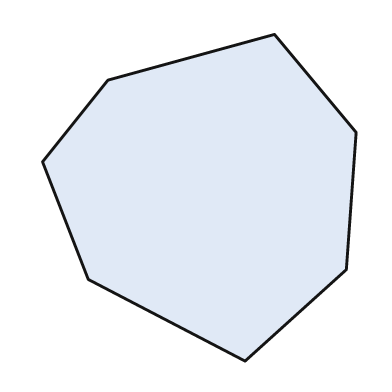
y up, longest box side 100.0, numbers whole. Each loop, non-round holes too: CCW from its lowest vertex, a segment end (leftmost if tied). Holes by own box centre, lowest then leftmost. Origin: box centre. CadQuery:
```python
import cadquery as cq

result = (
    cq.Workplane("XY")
    .moveTo(14.0, -50.0)
    .lineTo(45.0, -22.0)
    .lineTo(48.0, 20.0)
    .lineTo(23.0, 50.0)
    .lineTo(-28.0, 36.0)
    .lineTo(-48.0, 11.0)
    .lineTo(-34.0, -25.0)
    .close()
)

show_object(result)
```